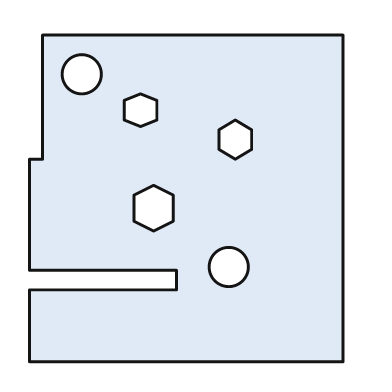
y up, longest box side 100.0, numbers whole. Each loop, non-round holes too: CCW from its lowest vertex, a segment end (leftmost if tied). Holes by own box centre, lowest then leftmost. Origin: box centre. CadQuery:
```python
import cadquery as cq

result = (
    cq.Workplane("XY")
    .moveTo(-48.0, -50.0)
    .lineTo(48.0, -50.0)
    .lineTo(48.0, 50.0)
    .lineTo(-44.0, 50.0)
    .lineTo(-44.0, 12.0)
    .lineTo(-48.0, 12.0)
    .lineTo(-48.0, -22.0)
    .lineTo(-3.0, -22.0)
    .lineTo(-3.0, -28.0)
    .lineTo(-48.0, -28.0)
    .close()
    .moveTo(13.0, -21.0)
    .circle(6.0)
    .moveTo(-10.0, -10.0)
    .lineTo(-4.0, -7.0)
    .lineTo(-4.0, 1.0)
    .lineTo(-10.0, 4.0)
    .lineTo(-16.0, 1.0)
    .lineTo(-16.0, -7.0)
    .close()
    .moveTo(15.0, 12.0)
    .lineTo(20.0, 15.0)
    .lineTo(20.0, 21.0)
    .lineTo(15.0, 24.0)
    .lineTo(10.0, 21.0)
    .lineTo(10.0, 15.0)
    .close()
    .moveTo(-14.0, 22.0)
    .lineTo(-9.0, 24.0)
    .lineTo(-9.0, 30.0)
    .lineTo(-14.0, 32.0)
    .lineTo(-19.0, 30.0)
    .lineTo(-19.0, 24.0)
    .close()
    .moveTo(-32.0, 38.0)
    .circle(6.0)
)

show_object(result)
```